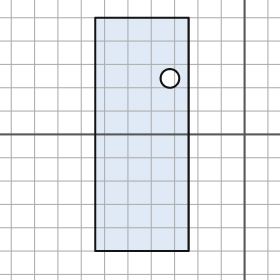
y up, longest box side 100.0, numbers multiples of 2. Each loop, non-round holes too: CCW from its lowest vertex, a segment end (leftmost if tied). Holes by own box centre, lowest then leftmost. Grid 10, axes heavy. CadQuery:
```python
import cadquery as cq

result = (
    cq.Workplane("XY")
    .moveTo(-64.0, -50.0)
    .lineTo(-24.0, -50.0)
    .lineTo(-24.0, 50.0)
    .lineTo(-64.0, 50.0)
    .close()
    .moveTo(-32.0, 24.0)
    .circle(4.0)
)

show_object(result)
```